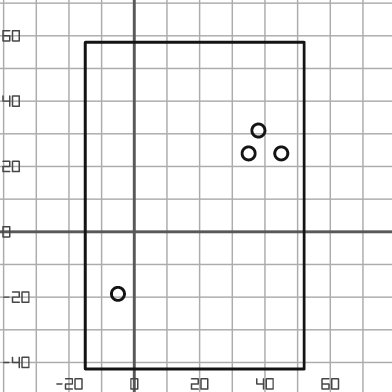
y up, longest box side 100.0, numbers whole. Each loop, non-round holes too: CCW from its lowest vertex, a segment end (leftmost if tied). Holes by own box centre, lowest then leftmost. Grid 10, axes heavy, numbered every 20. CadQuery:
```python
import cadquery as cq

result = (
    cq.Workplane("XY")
    .moveTo(-15.0, -42.0)
    .lineTo(52.0, -42.0)
    .lineTo(52.0, 58.0)
    .lineTo(-15.0, 58.0)
    .close()
    .moveTo(-5.0, -19.0)
    .circle(2.0)
    .moveTo(35.0, 24.0)
    .circle(2.0)
    .moveTo(45.0, 24.0)
    .circle(2.0)
    .moveTo(38.0, 31.0)
    .circle(2.0)
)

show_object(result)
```